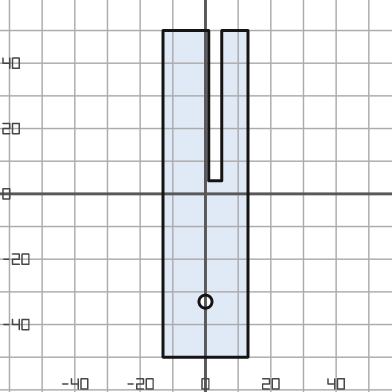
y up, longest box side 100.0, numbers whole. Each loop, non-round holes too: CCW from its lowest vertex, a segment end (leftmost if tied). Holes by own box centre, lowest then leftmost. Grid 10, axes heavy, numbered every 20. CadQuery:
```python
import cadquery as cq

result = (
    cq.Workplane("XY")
    .moveTo(-13.0, -50.0)
    .lineTo(13.0, -50.0)
    .lineTo(13.0, 50.0)
    .lineTo(5.0, 50.0)
    .lineTo(5.0, 4.0)
    .lineTo(1.0, 4.0)
    .lineTo(1.0, 50.0)
    .lineTo(-13.0, 50.0)
    .close()
    .moveTo(0.0, -33.0)
    .circle(2.0)
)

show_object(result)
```